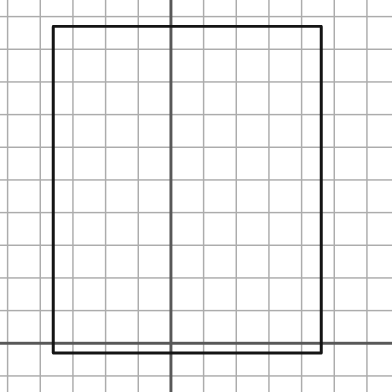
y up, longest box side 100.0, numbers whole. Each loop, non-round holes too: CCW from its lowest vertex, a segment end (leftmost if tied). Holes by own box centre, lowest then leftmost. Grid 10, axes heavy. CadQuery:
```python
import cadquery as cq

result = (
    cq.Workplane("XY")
    .moveTo(-36.0, -3.0)
    .lineTo(46.0, -3.0)
    .lineTo(46.0, 97.0)
    .lineTo(-36.0, 97.0)
    .close()
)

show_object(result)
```